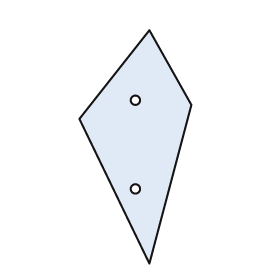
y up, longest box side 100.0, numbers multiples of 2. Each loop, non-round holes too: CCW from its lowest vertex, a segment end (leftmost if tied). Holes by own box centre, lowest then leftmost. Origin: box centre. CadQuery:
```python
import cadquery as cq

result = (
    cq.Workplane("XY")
    .moveTo(6.0, -50.0)
    .lineTo(24.0, 18.0)
    .lineTo(6.0, 50.0)
    .lineTo(-24.0, 12.0)
    .close()
    .moveTo(0.0, -18.0)
    .circle(2.0)
    .moveTo(0.0, 20.0)
    .circle(2.0)
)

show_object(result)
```